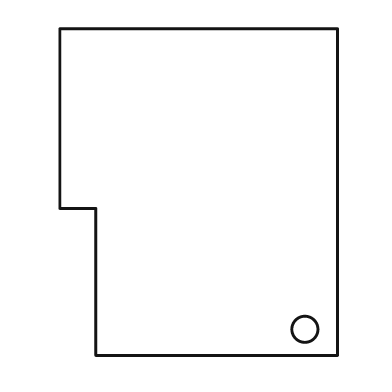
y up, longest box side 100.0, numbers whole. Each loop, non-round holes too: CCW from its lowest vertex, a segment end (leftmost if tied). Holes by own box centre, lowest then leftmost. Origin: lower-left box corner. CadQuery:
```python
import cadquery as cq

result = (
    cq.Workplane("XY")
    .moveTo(11.0, 0.0)
    .lineTo(85.0, 0.0)
    .lineTo(85.0, 100.0)
    .lineTo(0.0, 100.0)
    .lineTo(0.0, 45.0)
    .lineTo(11.0, 45.0)
    .close()
    .moveTo(75.0, 8.0)
    .circle(4.0)
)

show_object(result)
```